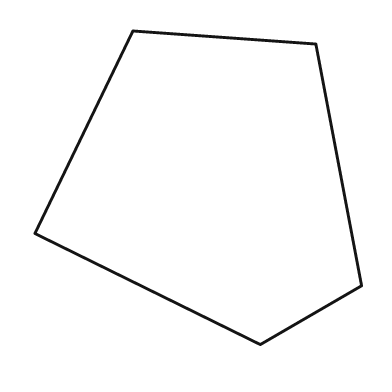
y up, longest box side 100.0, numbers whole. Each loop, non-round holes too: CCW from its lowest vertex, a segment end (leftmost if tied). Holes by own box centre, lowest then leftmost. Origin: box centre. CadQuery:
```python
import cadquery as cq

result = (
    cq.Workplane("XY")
    .moveTo(19.0, -48.0)
    .lineTo(50.0, -30.0)
    .lineTo(36.0, 44.0)
    .lineTo(-20.0, 48.0)
    .lineTo(-50.0, -14.0)
    .close()
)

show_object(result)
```